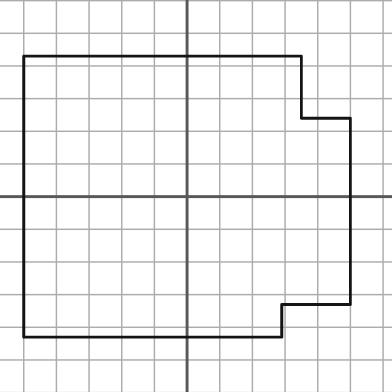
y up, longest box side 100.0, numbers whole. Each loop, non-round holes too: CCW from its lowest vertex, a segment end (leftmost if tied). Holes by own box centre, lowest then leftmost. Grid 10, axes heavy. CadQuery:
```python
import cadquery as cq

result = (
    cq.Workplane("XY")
    .moveTo(-50.0, -43.0)
    .lineTo(29.0, -43.0)
    .lineTo(29.0, -33.0)
    .lineTo(50.0, -33.0)
    .lineTo(50.0, 24.0)
    .lineTo(35.0, 24.0)
    .lineTo(35.0, 43.0)
    .lineTo(-50.0, 43.0)
    .close()
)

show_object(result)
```